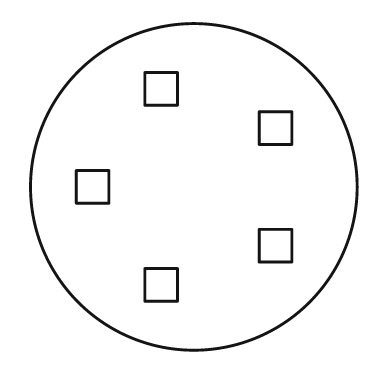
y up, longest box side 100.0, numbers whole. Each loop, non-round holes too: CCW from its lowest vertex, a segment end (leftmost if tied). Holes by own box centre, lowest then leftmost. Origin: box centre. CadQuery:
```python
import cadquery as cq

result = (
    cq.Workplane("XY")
    .moveTo(0.0, 0.0)
    .circle(50.0)
    .moveTo(-15.0, -35.0)
    .lineTo(-5.0, -35.0)
    .lineTo(-5.0, -25.0)
    .lineTo(-15.0, -25.0)
    .close()
    .moveTo(20.0, -23.0)
    .lineTo(30.0, -23.0)
    .lineTo(30.0, -13.0)
    .lineTo(20.0, -13.0)
    .close()
    .moveTo(-36.0, -5.0)
    .lineTo(-26.0, -5.0)
    .lineTo(-26.0, 5.0)
    .lineTo(-36.0, 5.0)
    .close()
    .moveTo(20.0, 13.0)
    .lineTo(30.0, 13.0)
    .lineTo(30.0, 23.0)
    .lineTo(20.0, 23.0)
    .close()
    .moveTo(-15.0, 25.0)
    .lineTo(-5.0, 25.0)
    .lineTo(-5.0, 35.0)
    .lineTo(-15.0, 35.0)
    .close()
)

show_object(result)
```